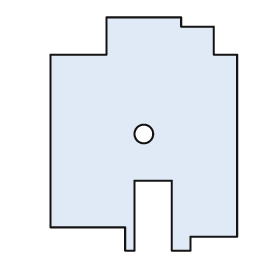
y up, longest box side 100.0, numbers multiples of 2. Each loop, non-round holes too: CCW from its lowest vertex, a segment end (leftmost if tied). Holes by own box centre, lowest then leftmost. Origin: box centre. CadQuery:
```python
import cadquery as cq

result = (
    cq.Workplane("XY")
    .moveTo(-8.0, -50.0)
    .lineTo(-4.0, -50.0)
    .lineTo(-4.0, -20.0)
    .lineTo(12.0, -20.0)
    .lineTo(12.0, -50.0)
    .lineTo(20.0, -50.0)
    .lineTo(20.0, -44.0)
    .lineTo(40.0, -44.0)
    .lineTo(40.0, 34.0)
    .lineTo(30.0, 34.0)
    .lineTo(30.0, 46.0)
    .lineTo(16.0, 46.0)
    .lineTo(16.0, 50.0)
    .lineTo(-16.0, 50.0)
    .lineTo(-16.0, 34.0)
    .lineTo(-40.0, 34.0)
    .lineTo(-40.0, -40.0)
    .lineTo(-8.0, -40.0)
    .close()
    .moveTo(0.0, 0.0)
    .circle(4.0)
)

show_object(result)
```